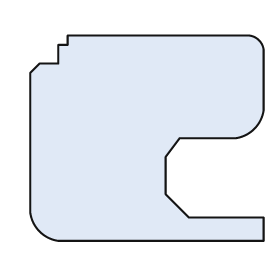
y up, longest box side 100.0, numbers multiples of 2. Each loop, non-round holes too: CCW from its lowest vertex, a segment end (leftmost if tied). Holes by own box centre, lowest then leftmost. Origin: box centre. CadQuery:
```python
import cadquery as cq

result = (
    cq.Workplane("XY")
    .moveTo(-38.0, -44.0)
    .lineTo(50.0, -44.0)
    .lineTo(50.0, -34.0)
    .lineTo(18.0, -34.0)
    .lineTo(8.0, -24.0)
    .lineTo(8.0, -8.0)
    .lineTo(14.0, 0.0)
    .lineTo(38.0, 0.0)
    .threePointArc((46.0, 4.0), (50.0, 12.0))
    .lineTo(50.0, 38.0)
    .threePointArc((48.0, 42.0), (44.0, 44.0))
    .lineTo(-34.0, 44.0)
    .lineTo(-34.0, 40.0)
    .lineTo(-38.0, 40.0)
    .lineTo(-38.0, 32.0)
    .lineTo(-46.0, 32.0)
    .lineTo(-50.0, 28.0)
    .lineTo(-50.0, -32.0)
    .threePointArc((-46.0, -40.0), (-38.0, -44.0))
    .close()
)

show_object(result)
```